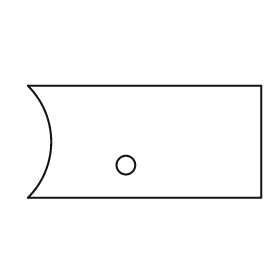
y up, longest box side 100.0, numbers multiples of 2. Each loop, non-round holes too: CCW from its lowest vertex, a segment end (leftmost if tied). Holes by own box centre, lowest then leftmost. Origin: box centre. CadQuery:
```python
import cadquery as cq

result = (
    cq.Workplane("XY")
    .moveTo(-50.0, -24.0)
    .lineTo(50.0, -24.0)
    .lineTo(50.0, 24.0)
    .lineTo(-50.0, 24.0)
    .threePointArc((-40.0, 0.0), (-50.0, -24.0))
    .close()
    .moveTo(-8.0, -10.0)
    .circle(4.0)
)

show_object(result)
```